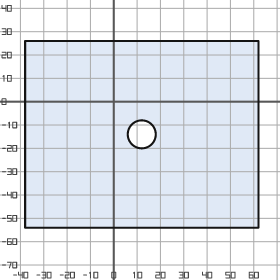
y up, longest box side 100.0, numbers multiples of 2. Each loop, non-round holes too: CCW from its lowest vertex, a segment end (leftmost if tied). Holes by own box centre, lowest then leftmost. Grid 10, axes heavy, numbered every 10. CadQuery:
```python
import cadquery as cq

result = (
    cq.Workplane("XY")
    .moveTo(-38.0, -54.0)
    .lineTo(62.0, -54.0)
    .lineTo(62.0, 26.0)
    .lineTo(-38.0, 26.0)
    .close()
    .moveTo(12.0, -14.0)
    .circle(6.0)
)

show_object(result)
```